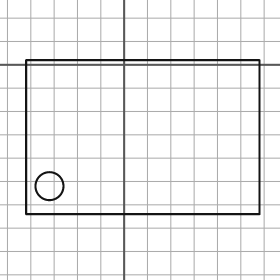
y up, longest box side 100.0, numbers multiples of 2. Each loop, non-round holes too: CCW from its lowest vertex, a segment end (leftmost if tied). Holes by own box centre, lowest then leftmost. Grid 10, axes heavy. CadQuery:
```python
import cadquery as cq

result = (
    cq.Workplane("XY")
    .moveTo(-42.0, -64.0)
    .lineTo(58.0, -64.0)
    .lineTo(58.0, 2.0)
    .lineTo(-42.0, 2.0)
    .close()
    .moveTo(-32.0, -52.0)
    .circle(6.0)
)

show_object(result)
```